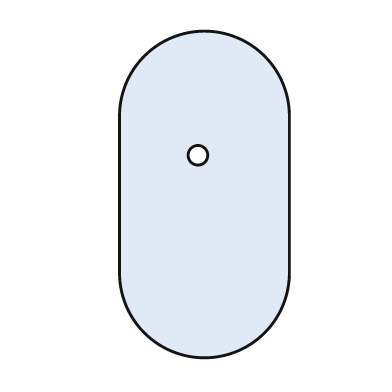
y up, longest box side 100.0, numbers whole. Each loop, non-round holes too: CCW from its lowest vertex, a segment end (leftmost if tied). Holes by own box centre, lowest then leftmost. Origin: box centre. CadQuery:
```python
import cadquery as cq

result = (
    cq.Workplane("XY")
    .moveTo(-26.0, -24.0)
    .threePointArc((0.0, -50.0), (26.0, -24.0))
    .lineTo(26.0, 24.0)
    .threePointArc((0.0, 50.0), (-26.0, 24.0))
    .close()
    .moveTo(-2.0, 12.0)
    .circle(3.0)
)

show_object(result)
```